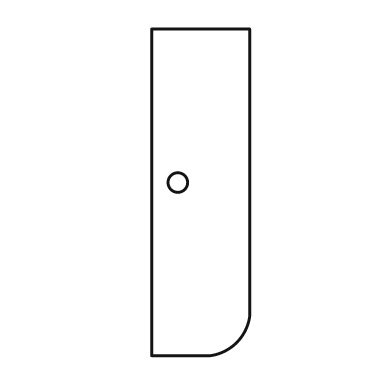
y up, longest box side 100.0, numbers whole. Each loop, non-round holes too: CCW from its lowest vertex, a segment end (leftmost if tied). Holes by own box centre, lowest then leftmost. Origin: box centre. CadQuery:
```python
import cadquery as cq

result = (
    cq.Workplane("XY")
    .moveTo(-15.0, -50.0)
    .lineTo(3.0, -50.0)
    .threePointArc((11.0, -46.0), (15.0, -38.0))
    .lineTo(15.0, 50.0)
    .lineTo(-15.0, 50.0)
    .close()
    .moveTo(-7.0, 3.0)
    .circle(3.0)
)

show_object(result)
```